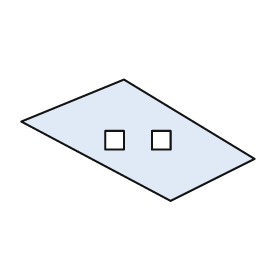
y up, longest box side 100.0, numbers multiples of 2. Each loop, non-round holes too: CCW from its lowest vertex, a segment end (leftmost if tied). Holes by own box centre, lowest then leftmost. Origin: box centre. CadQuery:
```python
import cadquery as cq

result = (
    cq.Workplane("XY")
    .moveTo(14.0, -26.0)
    .lineTo(50.0, -8.0)
    .lineTo(-6.0, 26.0)
    .lineTo(-50.0, 8.0)
    .close()
    .moveTo(-14.0, -4.0)
    .lineTo(-6.0, -4.0)
    .lineTo(-6.0, 4.0)
    .lineTo(-14.0, 4.0)
    .close()
    .moveTo(6.0, -4.0)
    .lineTo(14.0, -4.0)
    .lineTo(14.0, 4.0)
    .lineTo(6.0, 4.0)
    .close()
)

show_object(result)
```